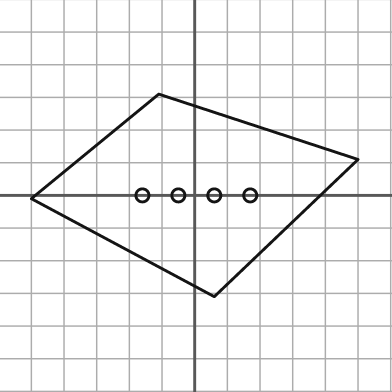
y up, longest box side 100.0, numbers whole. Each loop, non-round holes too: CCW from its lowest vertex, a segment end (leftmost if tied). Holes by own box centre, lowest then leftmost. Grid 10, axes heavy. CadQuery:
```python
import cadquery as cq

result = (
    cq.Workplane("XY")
    .moveTo(6.0, -31.0)
    .lineTo(50.0, 11.0)
    .lineTo(-11.0, 31.0)
    .lineTo(-50.0, -1.0)
    .close()
    .moveTo(-16.0, 0.0)
    .circle(2.0)
    .moveTo(-5.0, 0.0)
    .circle(2.0)
    .moveTo(6.0, 0.0)
    .circle(2.0)
    .moveTo(17.0, 0.0)
    .circle(2.0)
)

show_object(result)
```